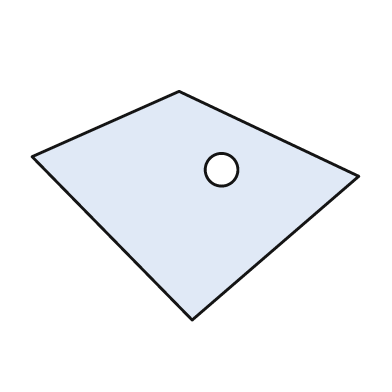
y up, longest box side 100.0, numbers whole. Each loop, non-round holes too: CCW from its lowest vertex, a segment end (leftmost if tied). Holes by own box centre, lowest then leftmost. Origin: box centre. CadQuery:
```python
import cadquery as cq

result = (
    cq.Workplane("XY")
    .moveTo(-1.0, -35.0)
    .lineTo(50.0, 9.0)
    .lineTo(-5.0, 35.0)
    .lineTo(-50.0, 15.0)
    .close()
    .moveTo(8.0, 11.0)
    .circle(5.0)
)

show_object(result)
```